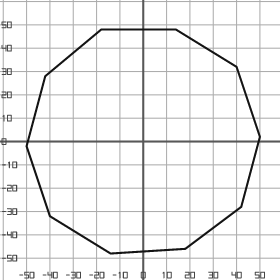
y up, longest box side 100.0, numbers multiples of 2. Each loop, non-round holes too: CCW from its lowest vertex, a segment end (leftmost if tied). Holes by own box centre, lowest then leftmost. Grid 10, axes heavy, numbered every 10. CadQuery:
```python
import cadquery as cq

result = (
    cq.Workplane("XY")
    .moveTo(-14.0, -48.0)
    .lineTo(18.0, -46.0)
    .lineTo(42.0, -28.0)
    .lineTo(50.0, 2.0)
    .lineTo(40.0, 32.0)
    .lineTo(14.0, 48.0)
    .lineTo(-18.0, 48.0)
    .lineTo(-42.0, 28.0)
    .lineTo(-50.0, -2.0)
    .lineTo(-40.0, -32.0)
    .close()
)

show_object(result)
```